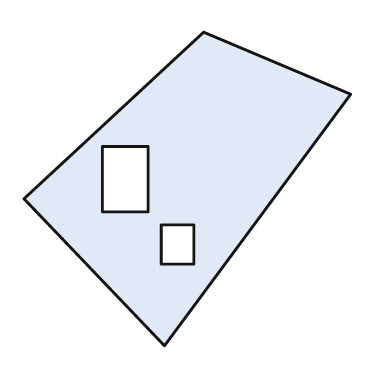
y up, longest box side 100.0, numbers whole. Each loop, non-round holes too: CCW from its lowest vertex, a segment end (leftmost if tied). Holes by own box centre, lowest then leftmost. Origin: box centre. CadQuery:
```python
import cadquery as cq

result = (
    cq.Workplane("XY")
    .moveTo(-7.0, -48.0)
    .lineTo(50.0, 29.0)
    .lineTo(5.0, 48.0)
    .lineTo(-50.0, -3.0)
    .close()
    .moveTo(-8.0, -23.0)
    .lineTo(2.0, -23.0)
    .lineTo(2.0, -11.0)
    .lineTo(-8.0, -11.0)
    .close()
    .moveTo(-26.0, -7.0)
    .lineTo(-12.0, -7.0)
    .lineTo(-12.0, 13.0)
    .lineTo(-26.0, 13.0)
    .close()
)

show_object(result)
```